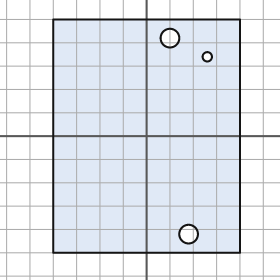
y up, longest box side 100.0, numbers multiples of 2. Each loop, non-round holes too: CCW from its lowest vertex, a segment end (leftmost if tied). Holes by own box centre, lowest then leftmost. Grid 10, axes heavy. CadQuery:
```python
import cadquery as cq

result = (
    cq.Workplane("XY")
    .moveTo(-40.0, -50.0)
    .lineTo(40.0, -50.0)
    .lineTo(40.0, 50.0)
    .lineTo(-40.0, 50.0)
    .close()
    .moveTo(18.0, -42.0)
    .circle(4.0)
    .moveTo(26.0, 34.0)
    .circle(2.0)
    .moveTo(10.0, 42.0)
    .circle(4.0)
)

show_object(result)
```